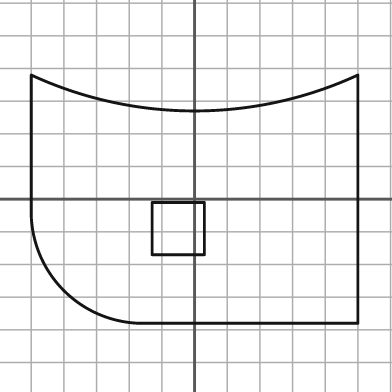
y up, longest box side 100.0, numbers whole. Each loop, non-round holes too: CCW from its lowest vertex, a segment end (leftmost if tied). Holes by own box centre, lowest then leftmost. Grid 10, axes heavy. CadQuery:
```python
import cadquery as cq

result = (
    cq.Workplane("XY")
    .moveTo(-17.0, -38.0)
    .lineTo(50.0, -38.0)
    .lineTo(50.0, 38.0)
    .threePointArc((0.0, 27.0), (-50.0, 38.0))
    .lineTo(-50.0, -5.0)
    .threePointArc((-40.0, -28.0), (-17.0, -38.0))
    .close()
    .moveTo(-13.0, -17.0)
    .lineTo(3.0, -17.0)
    .lineTo(3.0, -1.0)
    .lineTo(-13.0, -1.0)
    .close()
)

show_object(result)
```